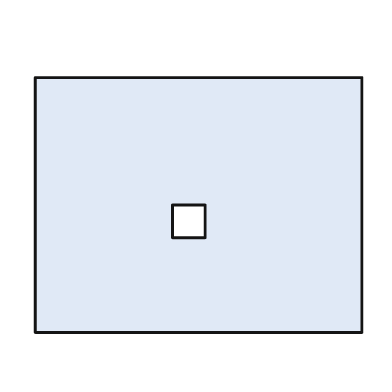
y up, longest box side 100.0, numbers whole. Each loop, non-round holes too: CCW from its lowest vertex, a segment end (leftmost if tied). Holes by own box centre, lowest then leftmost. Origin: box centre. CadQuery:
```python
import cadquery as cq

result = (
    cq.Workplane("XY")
    .moveTo(-50.0, -39.0)
    .lineTo(50.0, -39.0)
    .lineTo(50.0, 39.0)
    .lineTo(-50.0, 39.0)
    .close()
    .moveTo(-8.0, -10.0)
    .lineTo(2.0, -10.0)
    .lineTo(2.0, 0.0)
    .lineTo(-8.0, 0.0)
    .close()
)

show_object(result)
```